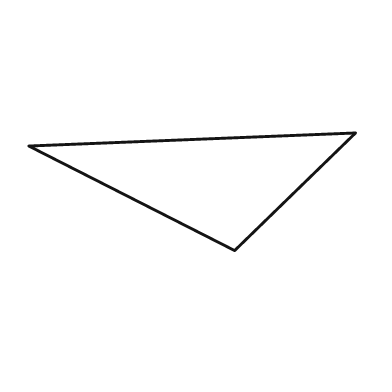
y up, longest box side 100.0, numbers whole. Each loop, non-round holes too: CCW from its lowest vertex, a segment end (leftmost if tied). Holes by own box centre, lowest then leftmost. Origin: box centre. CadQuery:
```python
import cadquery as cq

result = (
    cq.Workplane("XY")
    .moveTo(13.0, -18.0)
    .lineTo(50.0, 18.0)
    .lineTo(-50.0, 14.0)
    .close()
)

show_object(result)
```